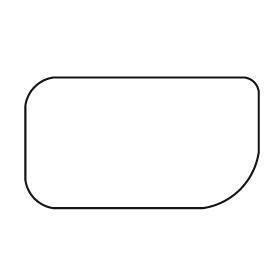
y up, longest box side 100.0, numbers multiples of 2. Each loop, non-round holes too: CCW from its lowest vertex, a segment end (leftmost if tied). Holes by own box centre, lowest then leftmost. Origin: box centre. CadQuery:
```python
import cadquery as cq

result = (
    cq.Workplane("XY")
    .moveTo(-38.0, -28.0)
    .lineTo(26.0, -28.0)
    .threePointArc((42.0, -20.0), (50.0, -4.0))
    .lineTo(50.0, 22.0)
    .threePointArc((48.0, 26.0), (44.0, 28.0))
    .lineTo(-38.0, 28.0)
    .threePointArc((-46.0, 24.0), (-50.0, 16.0))
    .lineTo(-50.0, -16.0)
    .threePointArc((-46.0, -24.0), (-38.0, -28.0))
    .close()
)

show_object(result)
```